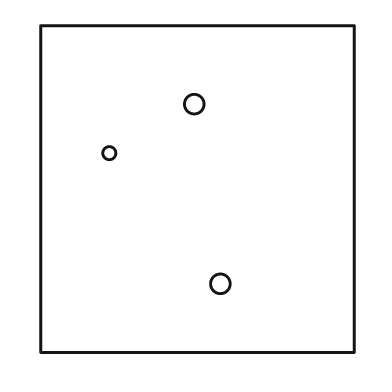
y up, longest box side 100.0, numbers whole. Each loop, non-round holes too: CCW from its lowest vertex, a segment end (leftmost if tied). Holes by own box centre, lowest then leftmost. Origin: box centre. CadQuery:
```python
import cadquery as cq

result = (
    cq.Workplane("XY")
    .moveTo(-48.0, -50.0)
    .lineTo(48.0, -50.0)
    .lineTo(48.0, 50.0)
    .lineTo(-48.0, 50.0)
    .close()
    .moveTo(7.0, -29.0)
    .circle(3.0)
    .moveTo(-27.0, 11.0)
    .circle(2.0)
    .moveTo(-1.0, 26.0)
    .circle(3.0)
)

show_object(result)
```